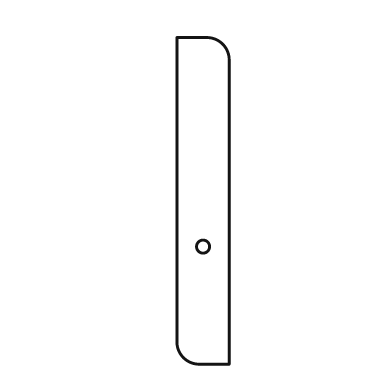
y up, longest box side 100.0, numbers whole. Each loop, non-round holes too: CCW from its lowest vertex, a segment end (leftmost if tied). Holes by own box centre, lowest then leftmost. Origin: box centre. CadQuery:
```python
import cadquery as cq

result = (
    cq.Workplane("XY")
    .moveTo(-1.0, -50.0)
    .lineTo(8.0, -50.0)
    .lineTo(8.0, 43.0)
    .threePointArc((6.0, 48.0), (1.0, 50.0))
    .lineTo(-8.0, 50.0)
    .lineTo(-8.0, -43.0)
    .threePointArc((-6.0, -48.0), (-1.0, -50.0))
    .close()
    .moveTo(0.0, -14.0)
    .circle(2.0)
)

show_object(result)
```